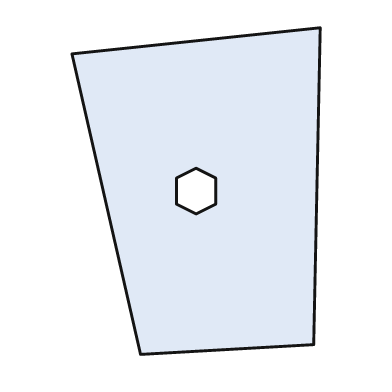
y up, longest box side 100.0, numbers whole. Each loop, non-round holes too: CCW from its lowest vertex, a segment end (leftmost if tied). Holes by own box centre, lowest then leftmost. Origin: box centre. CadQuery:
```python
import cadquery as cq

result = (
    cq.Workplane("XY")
    .moveTo(-17.0, -50.0)
    .lineTo(36.0, -47.0)
    .lineTo(38.0, 50.0)
    .lineTo(-38.0, 42.0)
    .close()
    .moveTo(0.0, -7.0)
    .lineTo(6.0, -4.0)
    .lineTo(6.0, 4.0)
    .lineTo(0.0, 7.0)
    .lineTo(-6.0, 4.0)
    .lineTo(-6.0, -4.0)
    .close()
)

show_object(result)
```